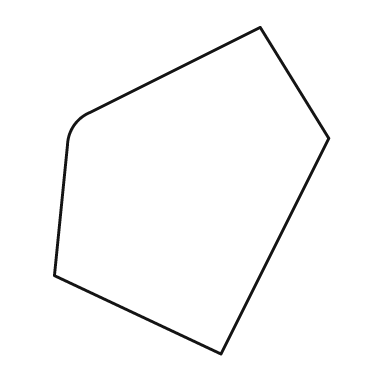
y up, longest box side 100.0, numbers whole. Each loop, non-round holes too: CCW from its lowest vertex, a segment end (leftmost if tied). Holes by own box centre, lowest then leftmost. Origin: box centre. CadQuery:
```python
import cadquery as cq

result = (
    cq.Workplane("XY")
    .moveTo(9.0, -50.0)
    .lineTo(42.0, 16.0)
    .lineTo(21.0, 50.0)
    .lineTo(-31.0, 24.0)
    .threePointArc((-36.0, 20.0), (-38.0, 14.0))
    .lineTo(-42.0, -26.0)
    .close()
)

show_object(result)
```